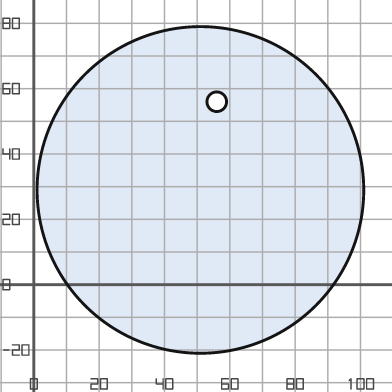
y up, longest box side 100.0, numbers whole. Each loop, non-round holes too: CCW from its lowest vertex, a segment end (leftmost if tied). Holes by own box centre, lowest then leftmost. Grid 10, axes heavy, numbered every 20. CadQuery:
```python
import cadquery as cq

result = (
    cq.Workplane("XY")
    .moveTo(51.0, 29.0)
    .circle(50.0)
    .moveTo(56.0, 56.0)
    .circle(3.0)
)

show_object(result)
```